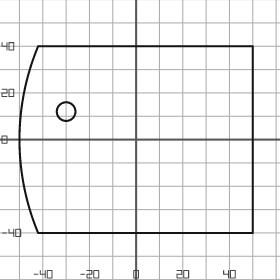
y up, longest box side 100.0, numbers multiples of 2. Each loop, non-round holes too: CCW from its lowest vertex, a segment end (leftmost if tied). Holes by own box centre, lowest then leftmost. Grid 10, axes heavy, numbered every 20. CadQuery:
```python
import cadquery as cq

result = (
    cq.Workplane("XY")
    .moveTo(-42.0, -40.0)
    .lineTo(50.0, -40.0)
    .lineTo(50.0, 40.0)
    .lineTo(-42.0, 40.0)
    .threePointArc((-50.0, 0.0), (-42.0, -40.0))
    .close()
    .moveTo(-30.0, 12.0)
    .circle(4.0)
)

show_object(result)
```